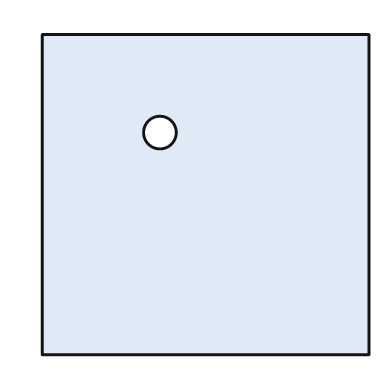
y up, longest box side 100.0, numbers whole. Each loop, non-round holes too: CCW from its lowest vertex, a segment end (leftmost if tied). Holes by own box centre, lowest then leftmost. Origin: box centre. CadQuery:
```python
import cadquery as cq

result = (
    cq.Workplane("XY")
    .moveTo(-50.0, -49.0)
    .lineTo(50.0, -49.0)
    .lineTo(50.0, 49.0)
    .lineTo(-50.0, 49.0)
    .close()
    .moveTo(-14.0, 19.0)
    .circle(5.0)
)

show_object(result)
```